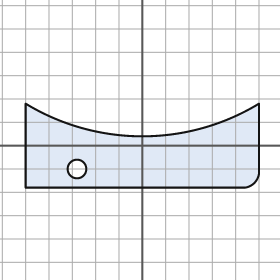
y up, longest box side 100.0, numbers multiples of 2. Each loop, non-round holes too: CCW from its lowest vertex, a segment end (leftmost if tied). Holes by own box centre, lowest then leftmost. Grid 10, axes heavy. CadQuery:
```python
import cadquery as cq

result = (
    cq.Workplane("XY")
    .moveTo(-50.0, -18.0)
    .lineTo(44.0, -18.0)
    .threePointArc((48.0, -16.0), (50.0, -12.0))
    .lineTo(50.0, 18.0)
    .threePointArc((0.0, 4.0), (-50.0, 18.0))
    .close()
    .moveTo(-28.0, -10.0)
    .circle(4.0)
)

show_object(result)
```